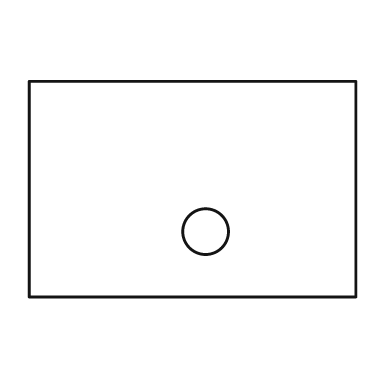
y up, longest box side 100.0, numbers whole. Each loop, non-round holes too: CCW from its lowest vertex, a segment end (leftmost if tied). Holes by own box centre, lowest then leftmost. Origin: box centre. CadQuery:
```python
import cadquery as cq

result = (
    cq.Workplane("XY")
    .moveTo(-50.0, -33.0)
    .lineTo(50.0, -33.0)
    .lineTo(50.0, 33.0)
    .lineTo(-50.0, 33.0)
    .close()
    .moveTo(4.0, -13.0)
    .circle(7.0)
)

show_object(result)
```